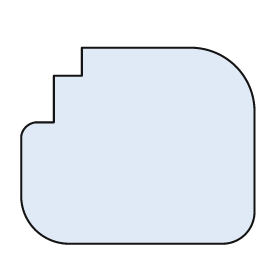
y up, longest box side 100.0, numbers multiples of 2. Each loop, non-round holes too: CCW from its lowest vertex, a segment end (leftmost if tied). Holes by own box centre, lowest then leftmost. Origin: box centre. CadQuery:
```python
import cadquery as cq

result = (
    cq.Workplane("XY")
    .moveTo(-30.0, -42.0)
    .lineTo(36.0, -42.0)
    .threePointArc((46.0, -38.0), (50.0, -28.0))
    .lineTo(50.0, 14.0)
    .threePointArc((42.0, 34.0), (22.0, 42.0))
    .lineTo(-24.0, 42.0)
    .lineTo(-24.0, 30.0)
    .lineTo(-36.0, 30.0)
    .lineTo(-36.0, 10.0)
    .lineTo(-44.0, 10.0)
    .threePointArc((-48.0, 8.0), (-50.0, 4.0))
    .lineTo(-50.0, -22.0)
    .threePointArc((-44.0, -36.0), (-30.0, -42.0))
    .close()
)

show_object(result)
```